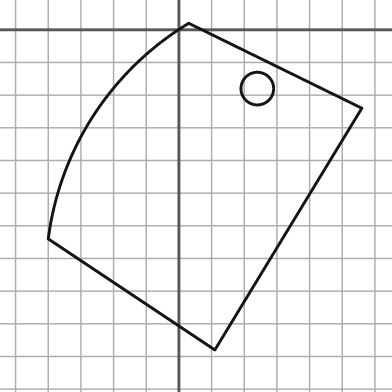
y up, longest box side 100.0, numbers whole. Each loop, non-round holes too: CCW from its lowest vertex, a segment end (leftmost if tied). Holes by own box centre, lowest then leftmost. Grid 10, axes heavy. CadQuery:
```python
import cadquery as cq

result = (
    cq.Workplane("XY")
    .moveTo(11.0, -98.0)
    .lineTo(56.0, -24.0)
    .lineTo(3.0, 2.0)
    .threePointArc((-26.0, -26.0), (-40.0, -64.0))
    .close()
    .moveTo(24.0, -18.0)
    .circle(5.0)
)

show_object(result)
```